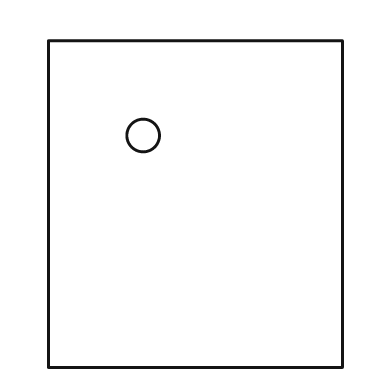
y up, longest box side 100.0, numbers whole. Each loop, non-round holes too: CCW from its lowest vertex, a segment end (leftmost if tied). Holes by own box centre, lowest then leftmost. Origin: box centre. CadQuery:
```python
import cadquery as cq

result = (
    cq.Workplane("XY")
    .moveTo(-45.0, -50.0)
    .lineTo(45.0, -50.0)
    .lineTo(45.0, 50.0)
    .lineTo(-45.0, 50.0)
    .close()
    .moveTo(-16.0, 21.0)
    .circle(5.0)
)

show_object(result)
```